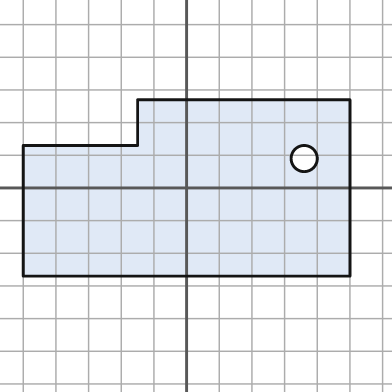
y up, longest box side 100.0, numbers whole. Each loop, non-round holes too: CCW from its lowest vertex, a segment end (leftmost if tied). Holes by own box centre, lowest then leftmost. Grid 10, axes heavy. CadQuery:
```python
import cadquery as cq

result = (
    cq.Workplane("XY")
    .moveTo(-50.0, -27.0)
    .lineTo(50.0, -27.0)
    .lineTo(50.0, 27.0)
    .lineTo(-15.0, 27.0)
    .lineTo(-15.0, 13.0)
    .lineTo(-50.0, 13.0)
    .close()
    .moveTo(36.0, 9.0)
    .circle(4.0)
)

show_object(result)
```